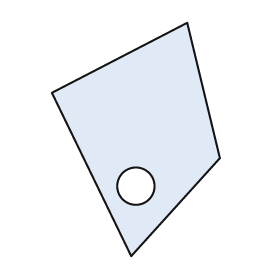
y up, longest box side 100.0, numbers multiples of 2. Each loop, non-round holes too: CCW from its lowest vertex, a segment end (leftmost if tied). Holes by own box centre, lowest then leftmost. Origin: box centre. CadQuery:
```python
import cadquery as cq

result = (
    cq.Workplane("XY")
    .moveTo(-2.0, -50.0)
    .lineTo(36.0, -8.0)
    .lineTo(22.0, 50.0)
    .lineTo(-36.0, 20.0)
    .close()
    .moveTo(0.0, -20.0)
    .circle(8.0)
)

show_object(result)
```